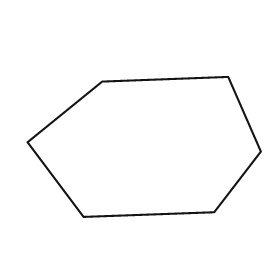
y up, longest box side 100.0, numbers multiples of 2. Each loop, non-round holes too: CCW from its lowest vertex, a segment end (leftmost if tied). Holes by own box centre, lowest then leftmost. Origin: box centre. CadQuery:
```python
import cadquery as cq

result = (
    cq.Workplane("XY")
    .moveTo(-26.0, -30.0)
    .lineTo(30.0, -28.0)
    .lineTo(50.0, -2.0)
    .lineTo(36.0, 30.0)
    .lineTo(-18.0, 28.0)
    .lineTo(-50.0, 2.0)
    .close()
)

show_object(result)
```